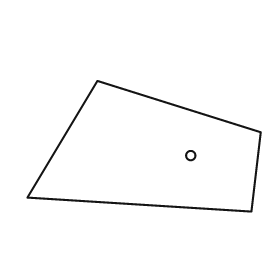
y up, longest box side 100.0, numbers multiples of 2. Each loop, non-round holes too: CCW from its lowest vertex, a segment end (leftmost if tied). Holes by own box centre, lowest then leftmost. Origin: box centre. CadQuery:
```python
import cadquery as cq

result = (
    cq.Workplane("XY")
    .moveTo(46.0, -28.0)
    .lineTo(50.0, 6.0)
    .lineTo(-20.0, 28.0)
    .lineTo(-50.0, -22.0)
    .close()
    .moveTo(20.0, -4.0)
    .circle(2.0)
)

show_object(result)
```